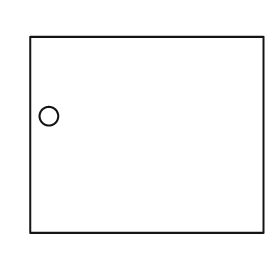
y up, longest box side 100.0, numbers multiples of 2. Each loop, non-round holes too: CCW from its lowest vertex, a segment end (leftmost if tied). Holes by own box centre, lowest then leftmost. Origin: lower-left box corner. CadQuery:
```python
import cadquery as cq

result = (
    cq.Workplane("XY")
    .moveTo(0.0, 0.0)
    .lineTo(100.0, 0.0)
    .lineTo(100.0, 84.0)
    .lineTo(0.0, 84.0)
    .close()
    .moveTo(8.0, 50.0)
    .circle(4.0)
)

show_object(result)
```